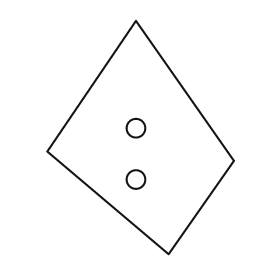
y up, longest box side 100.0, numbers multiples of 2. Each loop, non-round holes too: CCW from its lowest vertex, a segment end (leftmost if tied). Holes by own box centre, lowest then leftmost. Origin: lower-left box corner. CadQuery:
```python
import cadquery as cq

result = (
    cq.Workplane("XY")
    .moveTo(52.0, 0.0)
    .lineTo(80.0, 40.0)
    .lineTo(38.0, 100.0)
    .lineTo(0.0, 44.0)
    .close()
    .moveTo(38.0, 32.0)
    .circle(4.0)
    .moveTo(38.0, 54.0)
    .circle(4.0)
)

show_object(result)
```